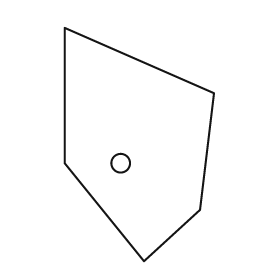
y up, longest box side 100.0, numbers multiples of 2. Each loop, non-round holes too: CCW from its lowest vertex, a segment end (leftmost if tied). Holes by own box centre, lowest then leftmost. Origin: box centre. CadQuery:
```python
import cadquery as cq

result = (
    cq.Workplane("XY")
    .moveTo(2.0, -50.0)
    .lineTo(26.0, -28.0)
    .lineTo(32.0, 22.0)
    .lineTo(-32.0, 50.0)
    .lineTo(-32.0, -8.0)
    .close()
    .moveTo(-8.0, -8.0)
    .circle(4.0)
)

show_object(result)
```